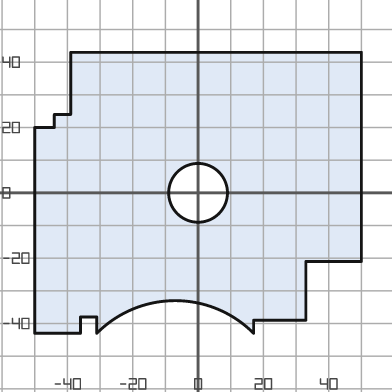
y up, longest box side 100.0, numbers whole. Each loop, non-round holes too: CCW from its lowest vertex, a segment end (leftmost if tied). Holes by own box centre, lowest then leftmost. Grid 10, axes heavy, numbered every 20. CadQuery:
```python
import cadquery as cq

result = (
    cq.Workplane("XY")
    .moveTo(-50.0, -43.0)
    .lineTo(-36.0, -43.0)
    .lineTo(-36.0, -38.0)
    .lineTo(-31.0, -38.0)
    .lineTo(-31.0, -43.0)
    .threePointArc((-7.0, -33.0), (17.0, -43.0))
    .lineTo(17.0, -39.0)
    .lineTo(33.0, -39.0)
    .lineTo(33.0, -21.0)
    .lineTo(50.0, -21.0)
    .lineTo(50.0, 43.0)
    .lineTo(-39.0, 43.0)
    .lineTo(-39.0, 24.0)
    .lineTo(-44.0, 24.0)
    .lineTo(-44.0, 20.0)
    .lineTo(-50.0, 20.0)
    .close()
    .moveTo(0.0, 0.0)
    .circle(9.0)
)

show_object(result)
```